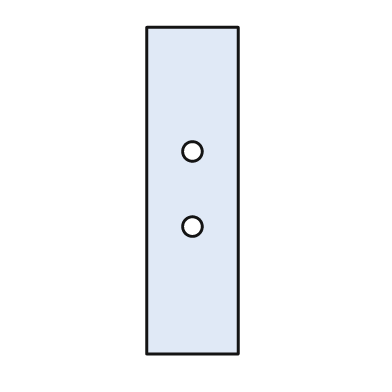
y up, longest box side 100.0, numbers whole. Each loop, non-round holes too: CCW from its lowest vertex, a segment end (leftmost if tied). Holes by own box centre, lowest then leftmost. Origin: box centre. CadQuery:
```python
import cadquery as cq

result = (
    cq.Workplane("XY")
    .moveTo(-14.0, -50.0)
    .lineTo(14.0, -50.0)
    .lineTo(14.0, 50.0)
    .lineTo(-14.0, 50.0)
    .close()
    .moveTo(0.0, -11.0)
    .circle(3.0)
    .moveTo(0.0, 12.0)
    .circle(3.0)
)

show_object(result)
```